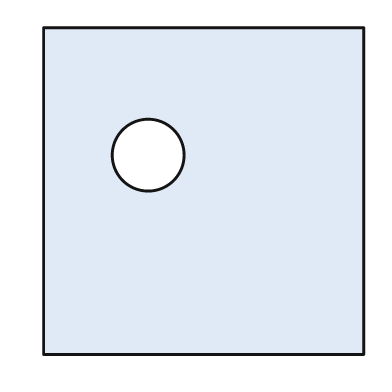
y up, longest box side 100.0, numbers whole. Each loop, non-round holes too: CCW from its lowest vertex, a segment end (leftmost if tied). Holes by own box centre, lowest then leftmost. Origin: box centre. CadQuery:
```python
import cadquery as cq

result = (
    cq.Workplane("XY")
    .moveTo(-49.0, -50.0)
    .lineTo(49.0, -50.0)
    .lineTo(49.0, 50.0)
    .lineTo(-49.0, 50.0)
    .close()
    .moveTo(-17.0, 11.0)
    .circle(11.0)
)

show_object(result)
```